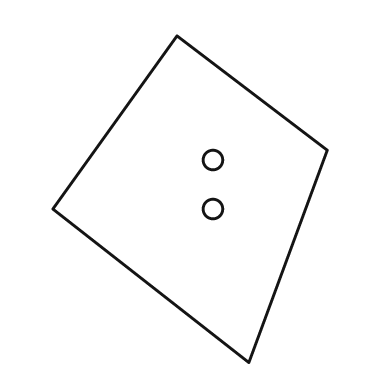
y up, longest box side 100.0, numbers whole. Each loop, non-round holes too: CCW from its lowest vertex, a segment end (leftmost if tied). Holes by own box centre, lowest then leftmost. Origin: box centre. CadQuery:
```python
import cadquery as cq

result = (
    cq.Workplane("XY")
    .moveTo(18.0, -50.0)
    .lineTo(42.0, 15.0)
    .lineTo(-4.0, 50.0)
    .lineTo(-42.0, -3.0)
    .close()
    .moveTo(7.0, -3.0)
    .circle(3.0)
    .moveTo(7.0, 12.0)
    .circle(3.0)
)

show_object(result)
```